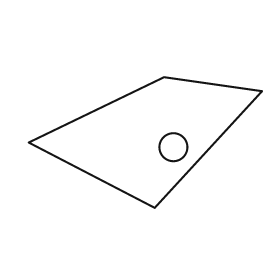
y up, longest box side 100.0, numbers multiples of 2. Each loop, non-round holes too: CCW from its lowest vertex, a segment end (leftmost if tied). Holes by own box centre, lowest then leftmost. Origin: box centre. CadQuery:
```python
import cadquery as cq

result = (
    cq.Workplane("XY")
    .moveTo(4.0, -28.0)
    .lineTo(50.0, 22.0)
    .lineTo(8.0, 28.0)
    .lineTo(-50.0, 0.0)
    .close()
    .moveTo(12.0, -2.0)
    .circle(6.0)
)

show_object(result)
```